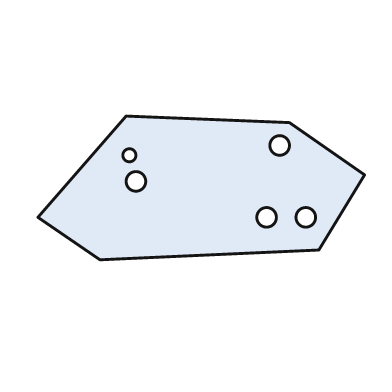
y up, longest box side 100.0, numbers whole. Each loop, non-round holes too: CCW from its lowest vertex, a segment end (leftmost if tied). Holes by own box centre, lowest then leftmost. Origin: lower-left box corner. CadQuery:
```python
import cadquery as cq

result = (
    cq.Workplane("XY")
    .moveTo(19.0, 0.0)
    .lineTo(86.0, 3.0)
    .lineTo(100.0, 26.0)
    .lineTo(77.0, 42.0)
    .lineTo(27.0, 44.0)
    .lineTo(0.0, 13.0)
    .close()
    .moveTo(70.0, 13.0)
    .circle(3.0)
    .moveTo(82.0, 13.0)
    .circle(3.0)
    .moveTo(30.0, 24.0)
    .circle(3.0)
    .moveTo(28.0, 32.0)
    .circle(2.0)
    .moveTo(74.0, 35.0)
    .circle(3.0)
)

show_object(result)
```